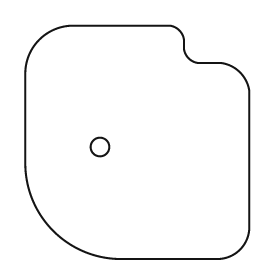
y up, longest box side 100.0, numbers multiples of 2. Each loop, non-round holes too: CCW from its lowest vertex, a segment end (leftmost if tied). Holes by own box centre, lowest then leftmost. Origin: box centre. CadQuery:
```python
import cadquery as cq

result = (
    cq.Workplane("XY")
    .moveTo(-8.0, -50.0)
    .lineTo(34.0, -50.0)
    .threePointArc((44.0, -46.0), (48.0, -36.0))
    .lineTo(48.0, 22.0)
    .threePointArc((44.0, 30.0), (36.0, 34.0))
    .lineTo(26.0, 34.0)
    .threePointArc((22.0, 36.0), (20.0, 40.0))
    .lineTo(20.0, 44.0)
    .threePointArc((18.0, 48.0), (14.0, 50.0))
    .lineTo(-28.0, 50.0)
    .threePointArc((-42.0, 44.0), (-48.0, 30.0))
    .lineTo(-48.0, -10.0)
    .threePointArc((-36.0, -38.0), (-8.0, -50.0))
    .close()
    .moveTo(-16.0, -2.0)
    .circle(4.0)
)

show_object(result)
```